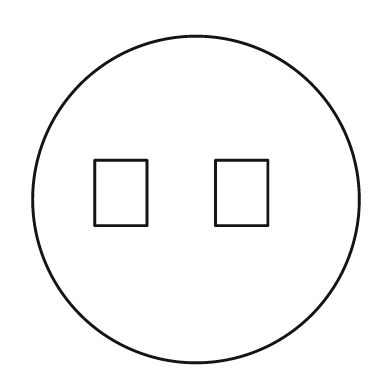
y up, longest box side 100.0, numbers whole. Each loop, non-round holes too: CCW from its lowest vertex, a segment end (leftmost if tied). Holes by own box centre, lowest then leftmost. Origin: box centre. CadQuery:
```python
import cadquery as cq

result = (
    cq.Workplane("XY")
    .moveTo(0.0, 0.0)
    .circle(50.0)
    .moveTo(-31.0, -8.0)
    .lineTo(-15.0, -8.0)
    .lineTo(-15.0, 12.0)
    .lineTo(-31.0, 12.0)
    .close()
    .moveTo(6.0, -8.0)
    .lineTo(22.0, -8.0)
    .lineTo(22.0, 12.0)
    .lineTo(6.0, 12.0)
    .close()
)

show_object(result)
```